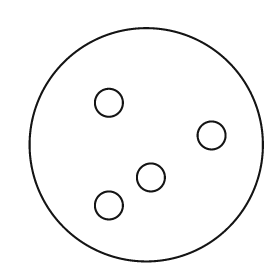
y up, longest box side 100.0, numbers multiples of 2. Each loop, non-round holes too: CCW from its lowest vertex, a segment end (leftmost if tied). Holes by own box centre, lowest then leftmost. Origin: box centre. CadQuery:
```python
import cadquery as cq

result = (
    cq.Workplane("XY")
    .moveTo(0.0, 0.0)
    .circle(50.0)
    .moveTo(-16.0, -26.0)
    .circle(6.0)
    .moveTo(2.0, -14.0)
    .circle(6.0)
    .moveTo(28.0, 4.0)
    .circle(6.0)
    .moveTo(-16.0, 18.0)
    .circle(6.0)
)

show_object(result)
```